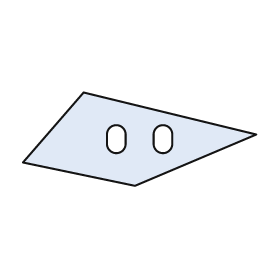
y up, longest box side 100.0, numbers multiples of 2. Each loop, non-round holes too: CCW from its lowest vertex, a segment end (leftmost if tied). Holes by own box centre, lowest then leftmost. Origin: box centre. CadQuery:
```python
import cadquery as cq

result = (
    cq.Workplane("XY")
    .moveTo(-2.0, -20.0)
    .lineTo(50.0, 2.0)
    .lineTo(-24.0, 20.0)
    .lineTo(-50.0, -10.0)
    .close()
    .moveTo(-14.0, -2.0)
    .threePointArc((-10.0, -6.0), (-6.0, -2.0))
    .lineTo(-6.0, 2.0)
    .threePointArc((-10.0, 6.0), (-14.0, 2.0))
    .close()
    .moveTo(6.0, -2.0)
    .threePointArc((10.0, -6.0), (14.0, -2.0))
    .lineTo(14.0, 2.0)
    .threePointArc((10.0, 6.0), (6.0, 2.0))
    .close()
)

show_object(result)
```